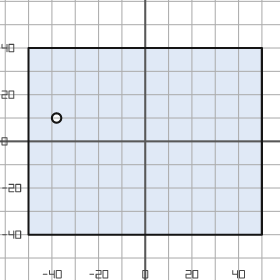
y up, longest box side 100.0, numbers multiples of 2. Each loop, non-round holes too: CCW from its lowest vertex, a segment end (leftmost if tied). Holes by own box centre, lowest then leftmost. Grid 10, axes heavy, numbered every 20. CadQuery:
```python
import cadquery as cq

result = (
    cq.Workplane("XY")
    .moveTo(-50.0, -40.0)
    .lineTo(50.0, -40.0)
    .lineTo(50.0, 40.0)
    .lineTo(-50.0, 40.0)
    .close()
    .moveTo(-38.0, 10.0)
    .circle(2.0)
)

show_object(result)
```